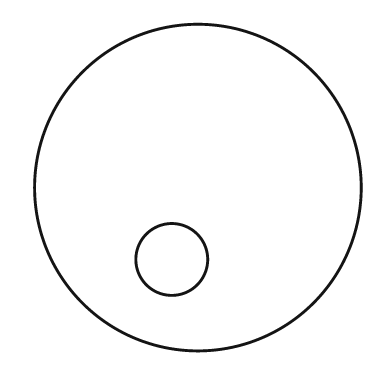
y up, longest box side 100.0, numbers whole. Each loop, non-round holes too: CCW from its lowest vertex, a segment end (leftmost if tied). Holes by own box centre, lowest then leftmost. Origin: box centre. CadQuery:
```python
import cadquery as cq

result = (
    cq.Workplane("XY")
    .moveTo(0.0, 0.0)
    .circle(50.0)
    .moveTo(-8.0, -22.0)
    .circle(11.0)
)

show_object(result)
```